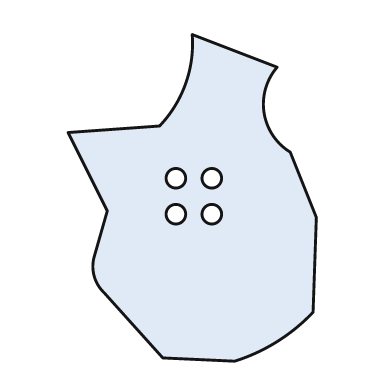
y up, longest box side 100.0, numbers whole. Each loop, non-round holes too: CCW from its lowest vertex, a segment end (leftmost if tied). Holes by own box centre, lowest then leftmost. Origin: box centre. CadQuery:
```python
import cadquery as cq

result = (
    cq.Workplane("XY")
    .moveTo(13.0, -50.0)
    .threePointArc((26.0, -44.0), (37.0, -35.0))
    .lineTo(38.0, -6.0)
    .lineTo(30.0, 14.0)
    .threePointArc((22.0, 26.0), (26.0, 40.0))
    .lineTo(0.0, 50.0)
    .threePointArc((-2.0, 35.0), (-10.0, 22.0))
    .lineTo(-38.0, 20.0)
    .lineTo(-26.0, -4.0)
    .lineTo(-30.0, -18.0)
    .threePointArc((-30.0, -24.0), (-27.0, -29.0))
    .lineTo(-9.0, -49.0)
    .close()
    .moveTo(-5.0, -5.0)
    .circle(3.0)
    .moveTo(6.0, -5.0)
    .circle(3.0)
    .moveTo(-5.0, 6.0)
    .circle(3.0)
    .moveTo(6.0, 6.0)
    .circle(3.0)
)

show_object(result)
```